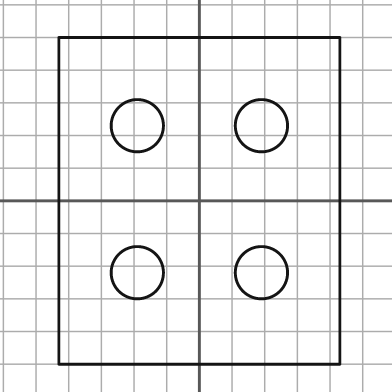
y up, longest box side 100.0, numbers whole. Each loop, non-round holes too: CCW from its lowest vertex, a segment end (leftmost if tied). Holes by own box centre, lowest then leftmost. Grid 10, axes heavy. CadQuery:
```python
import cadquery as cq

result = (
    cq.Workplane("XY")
    .moveTo(-43.0, -50.0)
    .lineTo(43.0, -50.0)
    .lineTo(43.0, 50.0)
    .lineTo(-43.0, 50.0)
    .close()
    .moveTo(-19.0, -22.0)
    .circle(8.0)
    .moveTo(19.0, -22.0)
    .circle(8.0)
    .moveTo(-19.0, 23.0)
    .circle(8.0)
    .moveTo(19.0, 23.0)
    .circle(8.0)
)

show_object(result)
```